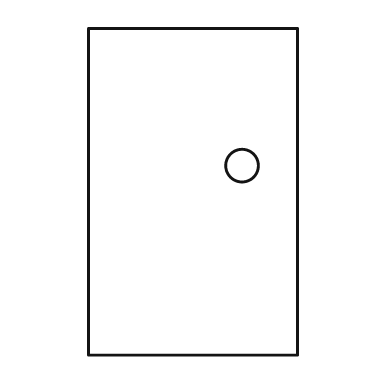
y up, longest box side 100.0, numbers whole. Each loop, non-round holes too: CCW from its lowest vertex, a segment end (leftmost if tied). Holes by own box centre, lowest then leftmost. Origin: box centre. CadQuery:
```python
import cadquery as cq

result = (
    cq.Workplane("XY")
    .moveTo(-32.0, -50.0)
    .lineTo(32.0, -50.0)
    .lineTo(32.0, 50.0)
    .lineTo(-32.0, 50.0)
    .close()
    .moveTo(15.0, 8.0)
    .circle(5.0)
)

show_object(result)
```